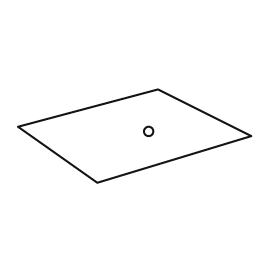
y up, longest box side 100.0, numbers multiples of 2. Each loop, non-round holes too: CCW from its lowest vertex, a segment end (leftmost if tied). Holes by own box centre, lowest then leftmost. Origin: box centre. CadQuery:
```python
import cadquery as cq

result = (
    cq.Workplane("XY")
    .moveTo(-16.0, -20.0)
    .lineTo(50.0, 0.0)
    .lineTo(10.0, 20.0)
    .lineTo(-50.0, 4.0)
    .close()
    .moveTo(6.0, 2.0)
    .circle(2.0)
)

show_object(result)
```